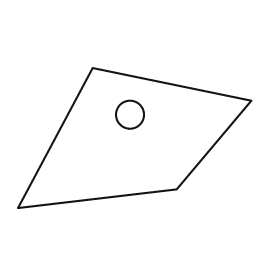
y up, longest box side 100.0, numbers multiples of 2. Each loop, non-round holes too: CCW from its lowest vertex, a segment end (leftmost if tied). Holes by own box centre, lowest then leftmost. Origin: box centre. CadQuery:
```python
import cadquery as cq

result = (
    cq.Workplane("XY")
    .moveTo(-50.0, -30.0)
    .lineTo(18.0, -22.0)
    .lineTo(50.0, 16.0)
    .lineTo(-18.0, 30.0)
    .close()
    .moveTo(-2.0, 10.0)
    .circle(6.0)
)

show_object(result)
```